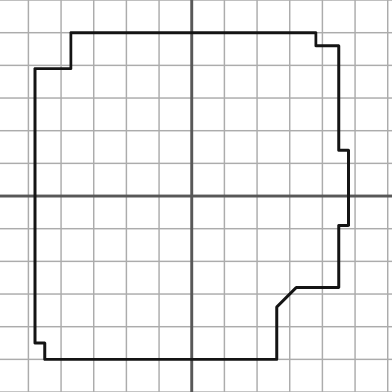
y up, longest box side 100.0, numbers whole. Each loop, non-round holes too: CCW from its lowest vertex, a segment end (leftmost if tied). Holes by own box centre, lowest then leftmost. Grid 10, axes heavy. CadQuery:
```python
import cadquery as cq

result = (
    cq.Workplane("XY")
    .moveTo(-45.0, -50.0)
    .lineTo(26.0, -50.0)
    .lineTo(26.0, -34.0)
    .lineTo(32.0, -28.0)
    .lineTo(45.0, -28.0)
    .lineTo(45.0, -9.0)
    .lineTo(48.0, -9.0)
    .lineTo(48.0, 14.0)
    .lineTo(45.0, 14.0)
    .lineTo(45.0, 46.0)
    .lineTo(38.0, 46.0)
    .lineTo(38.0, 50.0)
    .lineTo(-37.0, 50.0)
    .lineTo(-37.0, 39.0)
    .lineTo(-48.0, 39.0)
    .lineTo(-48.0, -45.0)
    .lineTo(-45.0, -45.0)
    .close()
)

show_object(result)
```